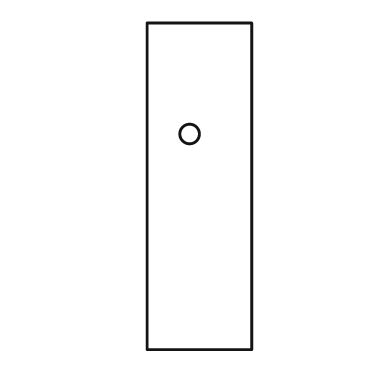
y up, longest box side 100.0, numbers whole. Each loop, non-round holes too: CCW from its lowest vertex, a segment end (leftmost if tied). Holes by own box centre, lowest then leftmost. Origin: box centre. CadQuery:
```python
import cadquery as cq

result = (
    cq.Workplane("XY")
    .moveTo(-16.0, -50.0)
    .lineTo(16.0, -50.0)
    .lineTo(16.0, 50.0)
    .lineTo(-16.0, 50.0)
    .close()
    .moveTo(-3.0, 16.0)
    .circle(3.0)
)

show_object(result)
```